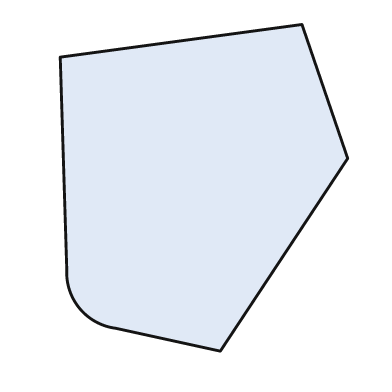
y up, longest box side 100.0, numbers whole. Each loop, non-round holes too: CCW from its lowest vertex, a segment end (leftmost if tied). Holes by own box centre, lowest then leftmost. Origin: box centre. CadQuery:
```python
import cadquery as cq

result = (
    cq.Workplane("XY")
    .moveTo(5.0, -50.0)
    .lineTo(44.0, 9.0)
    .lineTo(30.0, 50.0)
    .lineTo(-44.0, 40.0)
    .lineTo(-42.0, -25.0)
    .threePointArc((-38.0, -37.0), (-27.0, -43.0))
    .close()
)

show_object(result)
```